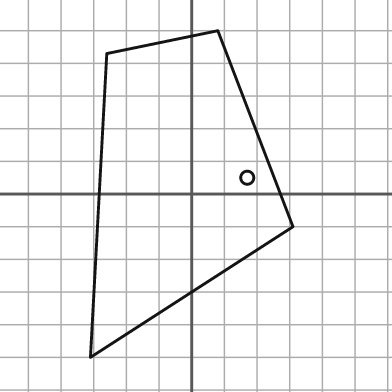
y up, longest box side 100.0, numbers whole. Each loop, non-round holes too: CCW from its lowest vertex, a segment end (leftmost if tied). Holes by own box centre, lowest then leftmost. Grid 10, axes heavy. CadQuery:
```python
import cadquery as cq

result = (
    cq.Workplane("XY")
    .moveTo(-31.0, -50.0)
    .lineTo(31.0, -10.0)
    .lineTo(8.0, 50.0)
    .lineTo(-26.0, 43.0)
    .close()
    .moveTo(17.0, 5.0)
    .circle(2.0)
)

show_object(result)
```